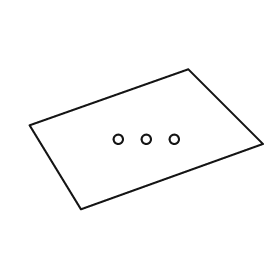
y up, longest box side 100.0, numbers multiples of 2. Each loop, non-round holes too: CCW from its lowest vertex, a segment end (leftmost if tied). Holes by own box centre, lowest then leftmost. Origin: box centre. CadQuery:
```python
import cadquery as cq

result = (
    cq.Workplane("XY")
    .moveTo(-28.0, -30.0)
    .lineTo(50.0, -2.0)
    .lineTo(18.0, 30.0)
    .lineTo(-50.0, 6.0)
    .close()
    .moveTo(-12.0, 0.0)
    .circle(2.0)
    .moveTo(0.0, 0.0)
    .circle(2.0)
    .moveTo(12.0, 0.0)
    .circle(2.0)
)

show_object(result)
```